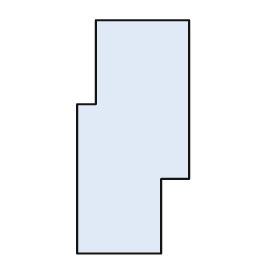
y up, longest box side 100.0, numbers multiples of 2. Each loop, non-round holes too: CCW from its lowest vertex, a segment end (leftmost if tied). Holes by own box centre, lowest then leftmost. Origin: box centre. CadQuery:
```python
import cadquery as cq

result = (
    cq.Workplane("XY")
    .moveTo(-24.0, -50.0)
    .lineTo(12.0, -50.0)
    .lineTo(12.0, -18.0)
    .lineTo(24.0, -18.0)
    .lineTo(24.0, 50.0)
    .lineTo(-16.0, 50.0)
    .lineTo(-16.0, 14.0)
    .lineTo(-24.0, 14.0)
    .close()
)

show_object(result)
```